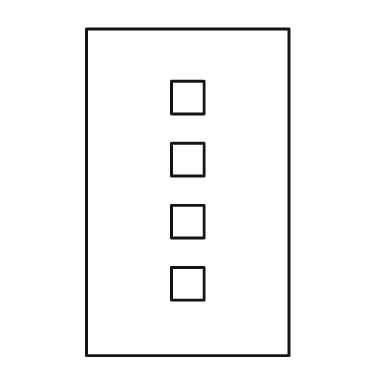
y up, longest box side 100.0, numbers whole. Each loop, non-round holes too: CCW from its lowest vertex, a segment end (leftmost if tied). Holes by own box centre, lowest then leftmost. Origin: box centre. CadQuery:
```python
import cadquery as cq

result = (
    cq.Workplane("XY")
    .moveTo(-31.0, -50.0)
    .lineTo(31.0, -50.0)
    .lineTo(31.0, 50.0)
    .lineTo(-31.0, 50.0)
    .close()
    .moveTo(-5.0, -33.0)
    .lineTo(5.0, -33.0)
    .lineTo(5.0, -23.0)
    .lineTo(-5.0, -23.0)
    .close()
    .moveTo(-5.0, -14.0)
    .lineTo(5.0, -14.0)
    .lineTo(5.0, -4.0)
    .lineTo(-5.0, -4.0)
    .close()
    .moveTo(-5.0, 5.0)
    .lineTo(5.0, 5.0)
    .lineTo(5.0, 15.0)
    .lineTo(-5.0, 15.0)
    .close()
    .moveTo(-5.0, 24.0)
    .lineTo(5.0, 24.0)
    .lineTo(5.0, 34.0)
    .lineTo(-5.0, 34.0)
    .close()
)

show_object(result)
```